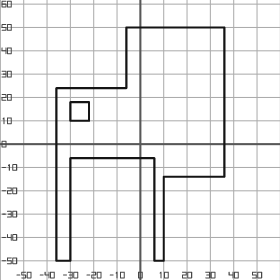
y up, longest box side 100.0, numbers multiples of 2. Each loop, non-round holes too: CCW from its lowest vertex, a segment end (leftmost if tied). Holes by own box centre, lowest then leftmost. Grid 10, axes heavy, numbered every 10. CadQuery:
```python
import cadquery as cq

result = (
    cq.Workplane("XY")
    .moveTo(-36.0, -50.0)
    .lineTo(-30.0, -50.0)
    .lineTo(-30.0, -6.0)
    .lineTo(6.0, -6.0)
    .lineTo(6.0, -50.0)
    .lineTo(10.0, -50.0)
    .lineTo(10.0, -14.0)
    .lineTo(36.0, -14.0)
    .lineTo(36.0, 50.0)
    .lineTo(-6.0, 50.0)
    .lineTo(-6.0, 24.0)
    .lineTo(-36.0, 24.0)
    .close()
    .moveTo(-30.0, 10.0)
    .lineTo(-22.0, 10.0)
    .lineTo(-22.0, 18.0)
    .lineTo(-30.0, 18.0)
    .close()
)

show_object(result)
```